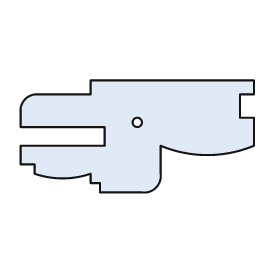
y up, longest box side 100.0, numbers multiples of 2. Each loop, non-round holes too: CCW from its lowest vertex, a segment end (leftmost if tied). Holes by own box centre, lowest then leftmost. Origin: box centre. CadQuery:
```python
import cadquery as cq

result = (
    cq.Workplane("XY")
    .moveTo(-16.0, -24.0)
    .lineTo(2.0, -24.0)
    .threePointArc((8.0, -22.0), (10.0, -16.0))
    .lineTo(10.0, -4.0)
    .threePointArc((30.0, -8.0), (50.0, -4.0))
    .lineTo(50.0, 8.0)
    .lineTo(44.0, 8.0)
    .lineTo(44.0, 18.0)
    .lineTo(50.0, 18.0)
    .lineTo(50.0, 24.0)
    .lineTo(-20.0, 24.0)
    .lineTo(-20.0, 18.0)
    .lineTo(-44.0, 18.0)
    .threePointArc((-48.0, 16.0), (-50.0, 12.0))
    .lineTo(-50.0, 4.0)
    .lineTo(-14.0, 4.0)
    .lineTo(-14.0, -4.0)
    .lineTo(-50.0, -4.0)
    .lineTo(-50.0, -12.0)
    .lineTo(-44.0, -12.0)
    .lineTo(-44.0, -16.0)
    .threePointArc((-32.0, -18.0), (-20.0, -16.0))
    .lineTo(-20.0, -20.0)
    .lineTo(-16.0, -20.0)
    .close()
    .moveTo(0.0, 6.0)
    .circle(2.0)
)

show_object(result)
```